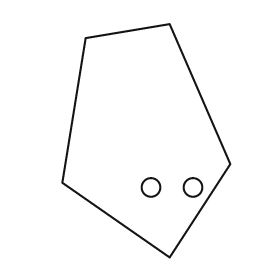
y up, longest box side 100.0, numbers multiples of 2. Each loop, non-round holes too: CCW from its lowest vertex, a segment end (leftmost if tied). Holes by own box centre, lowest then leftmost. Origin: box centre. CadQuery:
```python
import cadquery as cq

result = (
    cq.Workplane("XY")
    .moveTo(10.0, -50.0)
    .lineTo(36.0, -10.0)
    .lineTo(10.0, 50.0)
    .lineTo(-26.0, 44.0)
    .lineTo(-36.0, -18.0)
    .close()
    .moveTo(2.0, -20.0)
    .circle(4.0)
    .moveTo(20.0, -20.0)
    .circle(4.0)
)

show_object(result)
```